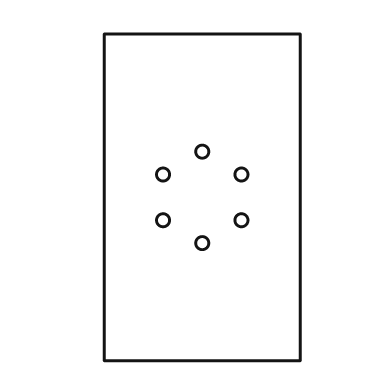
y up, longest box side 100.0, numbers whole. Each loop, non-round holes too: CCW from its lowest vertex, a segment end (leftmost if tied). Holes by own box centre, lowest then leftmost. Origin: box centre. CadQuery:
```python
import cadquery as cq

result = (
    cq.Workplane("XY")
    .moveTo(-30.0, -50.0)
    .lineTo(30.0, -50.0)
    .lineTo(30.0, 50.0)
    .lineTo(-30.0, 50.0)
    .close()
    .moveTo(0.0, -14.0)
    .circle(2.0)
    .moveTo(-12.0, -7.0)
    .circle(2.0)
    .moveTo(12.0, -7.0)
    .circle(2.0)
    .moveTo(-12.0, 7.0)
    .circle(2.0)
    .moveTo(12.0, 7.0)
    .circle(2.0)
    .moveTo(0.0, 14.0)
    .circle(2.0)
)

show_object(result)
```